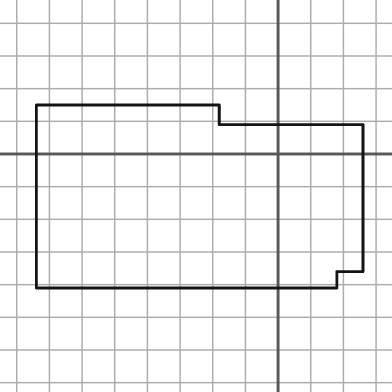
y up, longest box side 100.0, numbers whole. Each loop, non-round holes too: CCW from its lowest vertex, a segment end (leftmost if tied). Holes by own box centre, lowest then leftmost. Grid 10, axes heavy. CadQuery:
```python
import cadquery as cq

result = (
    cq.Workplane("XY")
    .moveTo(-74.0, -41.0)
    .lineTo(18.0, -41.0)
    .lineTo(18.0, -36.0)
    .lineTo(26.0, -36.0)
    .lineTo(26.0, 9.0)
    .lineTo(-18.0, 9.0)
    .lineTo(-18.0, 15.0)
    .lineTo(-74.0, 15.0)
    .close()
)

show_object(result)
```